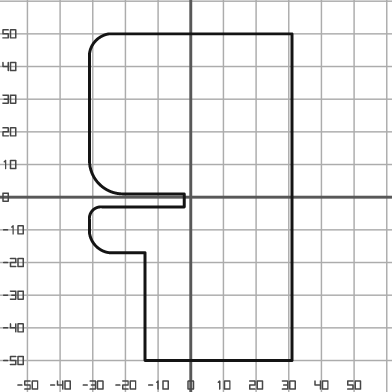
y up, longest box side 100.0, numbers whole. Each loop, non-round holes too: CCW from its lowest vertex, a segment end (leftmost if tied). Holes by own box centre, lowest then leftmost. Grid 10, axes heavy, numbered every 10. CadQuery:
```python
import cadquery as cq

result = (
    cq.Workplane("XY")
    .moveTo(-14.0, -50.0)
    .lineTo(31.0, -50.0)
    .lineTo(31.0, 50.0)
    .lineTo(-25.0, 50.0)
    .threePointArc((-29.0, 48.0), (-31.0, 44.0))
    .lineTo(-31.0, 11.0)
    .threePointArc((-28.0, 4.0), (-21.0, 1.0))
    .lineTo(-2.0, 1.0)
    .lineTo(-2.0, -3.0)
    .lineTo(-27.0, -3.0)
    .threePointArc((-30.0, -4.0), (-31.0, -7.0))
    .lineTo(-31.0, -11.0)
    .threePointArc((-29.0, -15.0), (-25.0, -17.0))
    .lineTo(-14.0, -17.0)
    .close()
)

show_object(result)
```